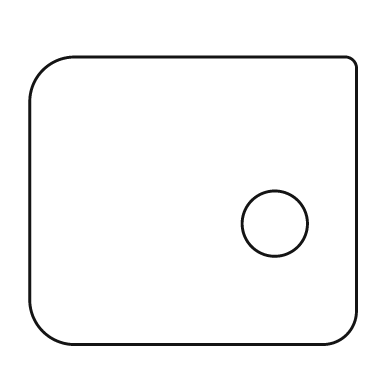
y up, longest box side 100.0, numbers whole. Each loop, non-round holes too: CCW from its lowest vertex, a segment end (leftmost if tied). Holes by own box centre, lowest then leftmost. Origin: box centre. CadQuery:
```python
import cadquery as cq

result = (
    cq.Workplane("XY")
    .moveTo(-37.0, -44.0)
    .lineTo(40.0, -44.0)
    .threePointArc((47.0, -41.0), (50.0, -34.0))
    .lineTo(50.0, 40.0)
    .threePointArc((49.0, 43.0), (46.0, 44.0))
    .lineTo(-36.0, 44.0)
    .threePointArc((-46.0, 40.0), (-50.0, 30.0))
    .lineTo(-50.0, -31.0)
    .threePointArc((-46.0, -40.0), (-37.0, -44.0))
    .close()
    .moveTo(25.0, -7.0)
    .circle(10.0)
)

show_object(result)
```